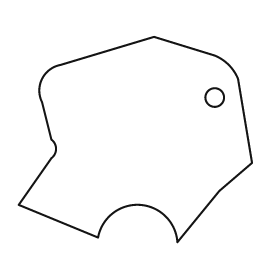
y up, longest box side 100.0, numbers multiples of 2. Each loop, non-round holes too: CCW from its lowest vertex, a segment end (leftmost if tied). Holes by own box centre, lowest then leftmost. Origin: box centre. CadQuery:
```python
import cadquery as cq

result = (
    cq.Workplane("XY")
    .moveTo(18.0, -44.0)
    .lineTo(36.0, -22.0)
    .lineTo(50.0, -10.0)
    .lineTo(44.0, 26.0)
    .threePointArc((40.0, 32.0), (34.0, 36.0))
    .lineTo(8.0, 44.0)
    .lineTo(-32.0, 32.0)
    .threePointArc((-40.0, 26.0), (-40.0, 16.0))
    .lineTo(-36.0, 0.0)
    .threePointArc((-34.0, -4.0), (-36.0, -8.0))
    .lineTo(-50.0, -28.0)
    .lineTo(-16.0, -42.0)
    .threePointArc((2.0, -28.0), (18.0, -44.0))
    .close()
    .moveTo(34.0, 18.0)
    .circle(4.0)
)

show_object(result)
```